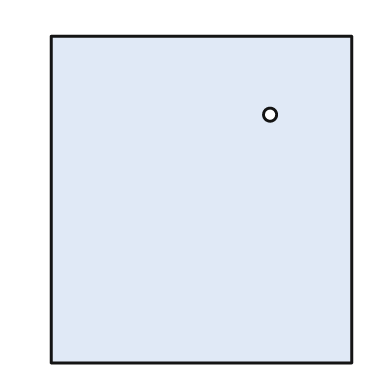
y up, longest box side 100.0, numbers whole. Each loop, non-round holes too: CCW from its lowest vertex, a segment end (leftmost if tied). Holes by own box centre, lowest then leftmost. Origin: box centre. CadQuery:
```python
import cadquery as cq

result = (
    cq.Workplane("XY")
    .moveTo(-46.0, -50.0)
    .lineTo(46.0, -50.0)
    .lineTo(46.0, 50.0)
    .lineTo(-46.0, 50.0)
    .close()
    .moveTo(21.0, 26.0)
    .circle(2.0)
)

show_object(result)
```